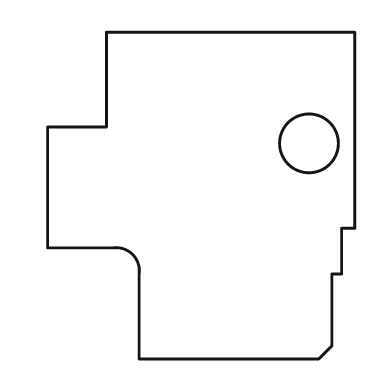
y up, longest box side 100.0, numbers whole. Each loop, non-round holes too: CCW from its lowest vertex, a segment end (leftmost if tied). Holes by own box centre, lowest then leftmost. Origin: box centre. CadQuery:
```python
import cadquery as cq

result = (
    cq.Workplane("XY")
    .moveTo(-19.0, -50.0)
    .lineTo(36.0, -50.0)
    .lineTo(40.0, -46.0)
    .lineTo(40.0, -24.0)
    .lineTo(43.0, -24.0)
    .lineTo(43.0, -10.0)
    .lineTo(47.0, -10.0)
    .lineTo(47.0, 50.0)
    .lineTo(-29.0, 50.0)
    .lineTo(-29.0, 21.0)
    .lineTo(-47.0, 21.0)
    .lineTo(-47.0, -16.0)
    .lineTo(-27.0, -16.0)
    .threePointArc((-21.0, -18.0), (-19.0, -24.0))
    .close()
    .moveTo(33.0, 16.0)
    .circle(9.0)
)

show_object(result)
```